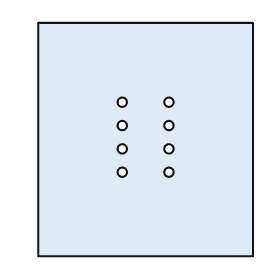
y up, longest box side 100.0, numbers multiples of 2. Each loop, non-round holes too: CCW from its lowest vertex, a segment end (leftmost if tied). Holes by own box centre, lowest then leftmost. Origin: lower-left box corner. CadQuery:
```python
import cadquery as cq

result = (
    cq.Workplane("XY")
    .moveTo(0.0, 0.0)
    .lineTo(92.0, 0.0)
    .lineTo(92.0, 100.0)
    .lineTo(0.0, 100.0)
    .close()
    .moveTo(36.0, 36.0)
    .circle(2.0)
    .moveTo(56.0, 36.0)
    .circle(2.0)
    .moveTo(36.0, 46.0)
    .circle(2.0)
    .moveTo(56.0, 46.0)
    .circle(2.0)
    .moveTo(36.0, 56.0)
    .circle(2.0)
    .moveTo(56.0, 56.0)
    .circle(2.0)
    .moveTo(36.0, 66.0)
    .circle(2.0)
    .moveTo(56.0, 66.0)
    .circle(2.0)
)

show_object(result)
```